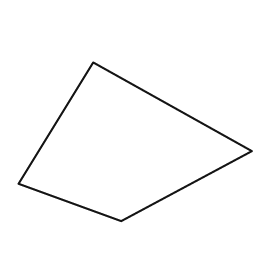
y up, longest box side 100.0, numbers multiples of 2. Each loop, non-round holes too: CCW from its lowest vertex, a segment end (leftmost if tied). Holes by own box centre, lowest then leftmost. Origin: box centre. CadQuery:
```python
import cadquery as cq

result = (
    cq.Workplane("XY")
    .moveTo(-6.0, -34.0)
    .lineTo(50.0, -4.0)
    .lineTo(-18.0, 34.0)
    .lineTo(-50.0, -18.0)
    .close()
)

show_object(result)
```